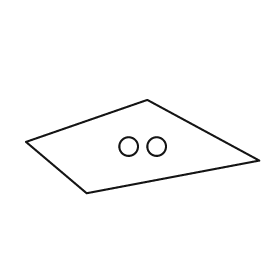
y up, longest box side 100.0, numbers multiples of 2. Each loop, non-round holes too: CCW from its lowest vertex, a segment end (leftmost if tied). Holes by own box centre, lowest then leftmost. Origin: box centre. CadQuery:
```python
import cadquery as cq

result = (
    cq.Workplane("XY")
    .moveTo(-24.0, -20.0)
    .lineTo(50.0, -6.0)
    .lineTo(2.0, 20.0)
    .lineTo(-50.0, 2.0)
    .close()
    .moveTo(-6.0, 0.0)
    .circle(4.0)
    .moveTo(6.0, 0.0)
    .circle(4.0)
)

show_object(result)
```